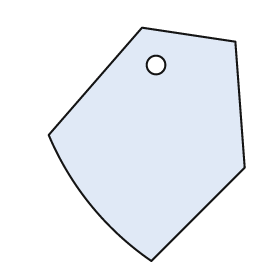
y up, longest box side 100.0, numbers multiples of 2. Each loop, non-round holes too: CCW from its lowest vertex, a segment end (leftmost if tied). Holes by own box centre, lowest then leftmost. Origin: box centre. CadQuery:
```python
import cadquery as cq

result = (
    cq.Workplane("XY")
    .moveTo(2.0, -50.0)
    .lineTo(42.0, -10.0)
    .lineTo(38.0, 44.0)
    .lineTo(-2.0, 50.0)
    .lineTo(-42.0, 4.0)
    .threePointArc((-24.0, -26.0), (2.0, -50.0))
    .close()
    .moveTo(4.0, 34.0)
    .circle(4.0)
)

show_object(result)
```